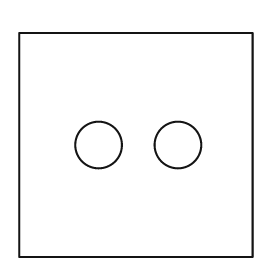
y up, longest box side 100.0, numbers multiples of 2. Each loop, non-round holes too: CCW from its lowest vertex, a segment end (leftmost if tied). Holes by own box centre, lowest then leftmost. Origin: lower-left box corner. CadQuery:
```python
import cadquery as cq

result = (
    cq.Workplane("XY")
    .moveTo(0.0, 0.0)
    .lineTo(100.0, 0.0)
    .lineTo(100.0, 96.0)
    .lineTo(0.0, 96.0)
    .close()
    .moveTo(34.0, 48.0)
    .circle(10.0)
    .moveTo(68.0, 48.0)
    .circle(10.0)
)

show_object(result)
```